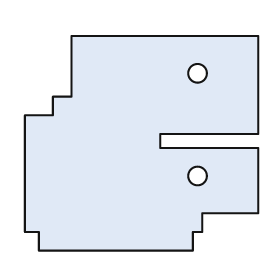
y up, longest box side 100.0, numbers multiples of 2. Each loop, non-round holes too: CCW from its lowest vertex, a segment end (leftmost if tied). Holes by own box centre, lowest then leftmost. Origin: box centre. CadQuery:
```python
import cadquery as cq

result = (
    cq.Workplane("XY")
    .moveTo(-44.0, -46.0)
    .lineTo(22.0, -46.0)
    .lineTo(22.0, -38.0)
    .lineTo(26.0, -38.0)
    .lineTo(26.0, -30.0)
    .lineTo(50.0, -30.0)
    .lineTo(50.0, -2.0)
    .lineTo(8.0, -2.0)
    .lineTo(8.0, 4.0)
    .lineTo(50.0, 4.0)
    .lineTo(50.0, 46.0)
    .lineTo(-30.0, 46.0)
    .lineTo(-30.0, 20.0)
    .lineTo(-38.0, 20.0)
    .lineTo(-38.0, 12.0)
    .lineTo(-50.0, 12.0)
    .lineTo(-50.0, -38.0)
    .lineTo(-44.0, -38.0)
    .close()
    .moveTo(24.0, -14.0)
    .circle(4.0)
    .moveTo(24.0, 30.0)
    .circle(4.0)
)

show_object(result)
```